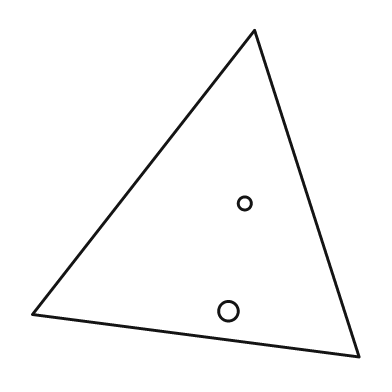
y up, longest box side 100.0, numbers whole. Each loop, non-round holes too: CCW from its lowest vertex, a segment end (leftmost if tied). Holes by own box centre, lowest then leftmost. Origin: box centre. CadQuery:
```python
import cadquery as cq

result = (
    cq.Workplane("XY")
    .moveTo(50.0, -50.0)
    .lineTo(18.0, 50.0)
    .lineTo(-50.0, -37.0)
    .close()
    .moveTo(10.0, -36.0)
    .circle(3.0)
    .moveTo(15.0, -3.0)
    .circle(2.0)
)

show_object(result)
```